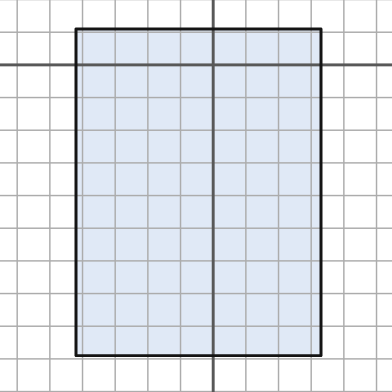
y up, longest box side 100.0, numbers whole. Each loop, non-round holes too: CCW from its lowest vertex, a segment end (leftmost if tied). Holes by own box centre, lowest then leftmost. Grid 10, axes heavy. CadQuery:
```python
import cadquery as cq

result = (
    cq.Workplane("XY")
    .moveTo(-42.0, -89.0)
    .lineTo(33.0, -89.0)
    .lineTo(33.0, 11.0)
    .lineTo(-42.0, 11.0)
    .close()
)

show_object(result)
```